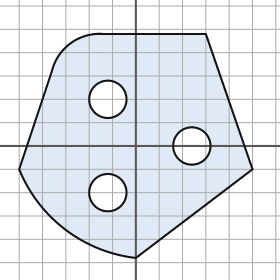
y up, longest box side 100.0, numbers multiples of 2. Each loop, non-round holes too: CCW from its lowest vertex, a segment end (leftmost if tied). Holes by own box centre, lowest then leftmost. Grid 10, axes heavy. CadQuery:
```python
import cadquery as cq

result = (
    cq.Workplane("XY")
    .moveTo(0.0, -48.0)
    .lineTo(50.0, -10.0)
    .lineTo(30.0, 48.0)
    .lineTo(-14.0, 48.0)
    .threePointArc((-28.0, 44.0), (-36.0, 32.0))
    .lineTo(-50.0, -10.0)
    .threePointArc((-30.0, -36.0), (0.0, -48.0))
    .close()
    .moveTo(-12.0, -20.0)
    .circle(8.0)
    .moveTo(24.0, 0.0)
    .circle(8.0)
    .moveTo(-12.0, 20.0)
    .circle(8.0)
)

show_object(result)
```